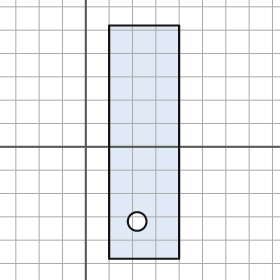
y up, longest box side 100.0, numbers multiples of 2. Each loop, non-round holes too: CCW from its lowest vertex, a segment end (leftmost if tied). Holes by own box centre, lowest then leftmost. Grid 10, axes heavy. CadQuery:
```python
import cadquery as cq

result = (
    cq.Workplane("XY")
    .moveTo(10.0, -48.0)
    .lineTo(40.0, -48.0)
    .lineTo(40.0, 52.0)
    .lineTo(10.0, 52.0)
    .close()
    .moveTo(22.0, -32.0)
    .circle(4.0)
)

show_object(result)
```